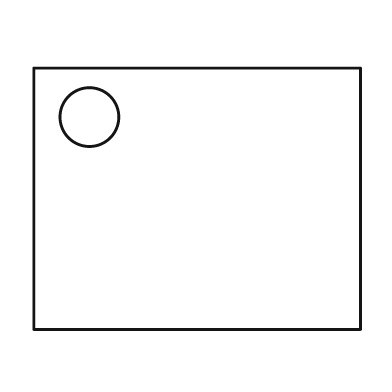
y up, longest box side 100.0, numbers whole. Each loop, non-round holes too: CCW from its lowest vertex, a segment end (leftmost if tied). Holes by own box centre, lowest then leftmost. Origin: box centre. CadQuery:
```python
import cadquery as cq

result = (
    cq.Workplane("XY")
    .moveTo(-50.0, -40.0)
    .lineTo(50.0, -40.0)
    .lineTo(50.0, 40.0)
    .lineTo(-50.0, 40.0)
    .close()
    .moveTo(-33.0, 25.0)
    .circle(9.0)
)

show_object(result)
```